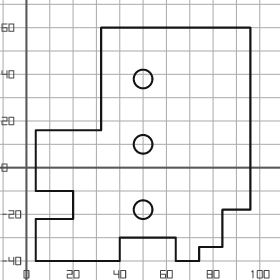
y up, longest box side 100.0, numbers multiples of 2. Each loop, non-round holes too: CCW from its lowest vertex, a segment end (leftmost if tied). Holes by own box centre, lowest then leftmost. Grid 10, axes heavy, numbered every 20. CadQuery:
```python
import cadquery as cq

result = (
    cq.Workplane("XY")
    .moveTo(4.0, -40.0)
    .lineTo(40.0, -40.0)
    .lineTo(40.0, -30.0)
    .lineTo(64.0, -30.0)
    .lineTo(64.0, -40.0)
    .lineTo(74.0, -40.0)
    .lineTo(74.0, -34.0)
    .lineTo(84.0, -34.0)
    .lineTo(84.0, -18.0)
    .lineTo(96.0, -18.0)
    .lineTo(96.0, 60.0)
    .lineTo(32.0, 60.0)
    .lineTo(32.0, 16.0)
    .lineTo(4.0, 16.0)
    .lineTo(4.0, -10.0)
    .lineTo(20.0, -10.0)
    .lineTo(20.0, -22.0)
    .lineTo(4.0, -22.0)
    .close()
    .moveTo(50.0, -18.0)
    .circle(4.0)
    .moveTo(50.0, 10.0)
    .circle(4.0)
    .moveTo(50.0, 38.0)
    .circle(4.0)
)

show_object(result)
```